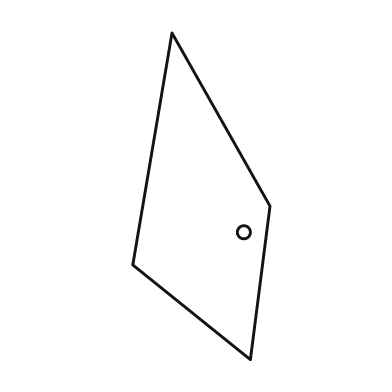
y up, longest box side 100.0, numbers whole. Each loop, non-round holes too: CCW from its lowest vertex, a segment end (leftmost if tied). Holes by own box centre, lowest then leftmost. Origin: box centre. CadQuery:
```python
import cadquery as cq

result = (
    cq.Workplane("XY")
    .moveTo(15.0, -50.0)
    .lineTo(21.0, -3.0)
    .lineTo(-9.0, 50.0)
    .lineTo(-21.0, -21.0)
    .close()
    .moveTo(13.0, -11.0)
    .circle(2.0)
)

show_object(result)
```